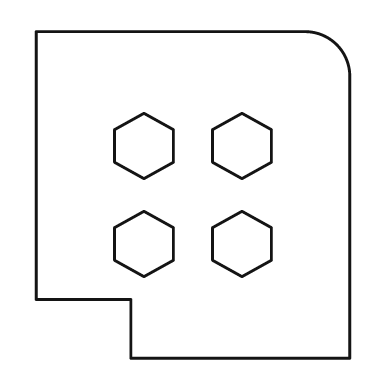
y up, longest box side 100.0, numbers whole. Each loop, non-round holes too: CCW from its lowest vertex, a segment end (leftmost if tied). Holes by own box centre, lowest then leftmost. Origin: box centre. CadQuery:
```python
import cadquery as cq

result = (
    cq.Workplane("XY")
    .moveTo(-19.0, -50.0)
    .lineTo(48.0, -50.0)
    .lineTo(48.0, 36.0)
    .threePointArc((44.0, 46.0), (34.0, 50.0))
    .lineTo(-48.0, 50.0)
    .lineTo(-48.0, -32.0)
    .lineTo(-19.0, -32.0)
    .close()
    .moveTo(-15.0, -25.0)
    .lineTo(-6.0, -20.0)
    .lineTo(-6.0, -10.0)
    .lineTo(-15.0, -5.0)
    .lineTo(-24.0, -10.0)
    .lineTo(-24.0, -20.0)
    .close()
    .moveTo(15.0, -25.0)
    .lineTo(24.0, -20.0)
    .lineTo(24.0, -10.0)
    .lineTo(15.0, -5.0)
    .lineTo(6.0, -10.0)
    .lineTo(6.0, -20.0)
    .close()
    .moveTo(-15.0, 5.0)
    .lineTo(-6.0, 10.0)
    .lineTo(-6.0, 20.0)
    .lineTo(-15.0, 25.0)
    .lineTo(-24.0, 20.0)
    .lineTo(-24.0, 10.0)
    .close()
    .moveTo(15.0, 5.0)
    .lineTo(24.0, 10.0)
    .lineTo(24.0, 20.0)
    .lineTo(15.0, 25.0)
    .lineTo(6.0, 20.0)
    .lineTo(6.0, 10.0)
    .close()
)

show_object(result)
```